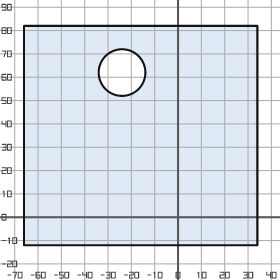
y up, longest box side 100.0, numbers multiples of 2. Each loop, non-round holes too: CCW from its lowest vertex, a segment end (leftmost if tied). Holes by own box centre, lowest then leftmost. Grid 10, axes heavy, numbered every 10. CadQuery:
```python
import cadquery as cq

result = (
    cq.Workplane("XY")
    .moveTo(-66.0, -12.0)
    .lineTo(34.0, -12.0)
    .lineTo(34.0, 82.0)
    .lineTo(-66.0, 82.0)
    .close()
    .moveTo(-24.0, 62.0)
    .circle(10.0)
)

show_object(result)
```